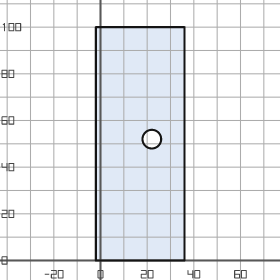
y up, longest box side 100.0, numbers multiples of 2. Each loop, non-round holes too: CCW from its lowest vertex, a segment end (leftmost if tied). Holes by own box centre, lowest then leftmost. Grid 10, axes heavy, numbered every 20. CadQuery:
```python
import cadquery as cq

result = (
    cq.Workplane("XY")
    .moveTo(-2.0, 0.0)
    .lineTo(36.0, 0.0)
    .lineTo(36.0, 100.0)
    .lineTo(-2.0, 100.0)
    .close()
    .moveTo(22.0, 52.0)
    .circle(4.0)
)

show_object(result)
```